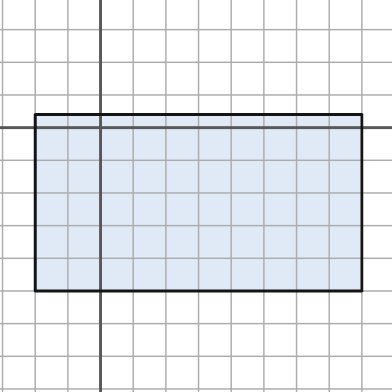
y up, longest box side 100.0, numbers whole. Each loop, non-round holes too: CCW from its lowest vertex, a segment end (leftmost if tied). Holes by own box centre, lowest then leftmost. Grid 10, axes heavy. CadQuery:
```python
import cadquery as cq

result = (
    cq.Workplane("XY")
    .moveTo(-20.0, -50.0)
    .lineTo(80.0, -50.0)
    .lineTo(80.0, 4.0)
    .lineTo(-20.0, 4.0)
    .close()
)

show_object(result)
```